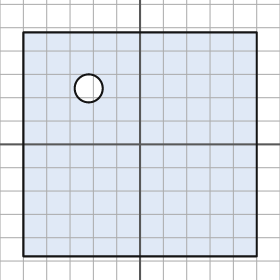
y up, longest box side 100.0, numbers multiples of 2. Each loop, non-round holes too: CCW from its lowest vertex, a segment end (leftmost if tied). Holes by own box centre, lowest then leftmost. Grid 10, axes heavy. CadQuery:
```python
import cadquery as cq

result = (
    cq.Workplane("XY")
    .moveTo(-50.0, -48.0)
    .lineTo(50.0, -48.0)
    .lineTo(50.0, 48.0)
    .lineTo(-50.0, 48.0)
    .close()
    .moveTo(-22.0, 24.0)
    .circle(6.0)
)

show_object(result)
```